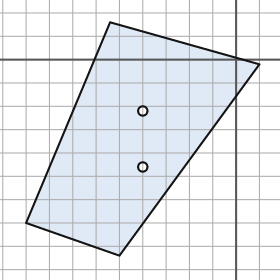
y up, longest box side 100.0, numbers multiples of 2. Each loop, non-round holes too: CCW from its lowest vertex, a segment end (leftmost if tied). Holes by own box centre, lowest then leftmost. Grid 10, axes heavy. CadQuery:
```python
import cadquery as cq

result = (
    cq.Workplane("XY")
    .moveTo(-50.0, -84.0)
    .lineTo(10.0, -2.0)
    .lineTo(-54.0, 16.0)
    .lineTo(-90.0, -70.0)
    .close()
    .moveTo(-40.0, -46.0)
    .circle(2.0)
    .moveTo(-40.0, -22.0)
    .circle(2.0)
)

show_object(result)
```